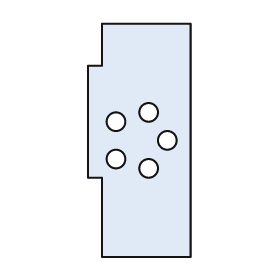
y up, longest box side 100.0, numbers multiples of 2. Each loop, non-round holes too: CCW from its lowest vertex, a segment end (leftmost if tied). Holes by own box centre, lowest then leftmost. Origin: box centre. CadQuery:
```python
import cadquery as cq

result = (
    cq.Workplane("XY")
    .moveTo(-16.0, -50.0)
    .lineTo(22.0, -50.0)
    .lineTo(22.0, 50.0)
    .lineTo(-16.0, 50.0)
    .lineTo(-16.0, 32.0)
    .lineTo(-22.0, 32.0)
    .lineTo(-22.0, -16.0)
    .lineTo(-16.0, -16.0)
    .close()
    .moveTo(4.0, -12.0)
    .circle(4.0)
    .moveTo(-10.0, -8.0)
    .circle(4.0)
    .moveTo(12.0, 0.0)
    .circle(4.0)
    .moveTo(-10.0, 8.0)
    .circle(4.0)
    .moveTo(4.0, 12.0)
    .circle(4.0)
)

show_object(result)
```